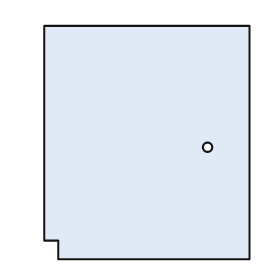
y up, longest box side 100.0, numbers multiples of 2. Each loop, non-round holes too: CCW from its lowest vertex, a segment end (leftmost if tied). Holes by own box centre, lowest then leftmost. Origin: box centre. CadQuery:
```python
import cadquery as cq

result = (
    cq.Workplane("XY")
    .moveTo(-38.0, -50.0)
    .lineTo(44.0, -50.0)
    .lineTo(44.0, 50.0)
    .lineTo(-44.0, 50.0)
    .lineTo(-44.0, -42.0)
    .lineTo(-38.0, -42.0)
    .close()
    .moveTo(26.0, -2.0)
    .circle(2.0)
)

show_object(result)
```